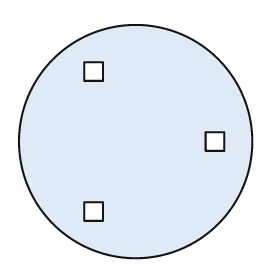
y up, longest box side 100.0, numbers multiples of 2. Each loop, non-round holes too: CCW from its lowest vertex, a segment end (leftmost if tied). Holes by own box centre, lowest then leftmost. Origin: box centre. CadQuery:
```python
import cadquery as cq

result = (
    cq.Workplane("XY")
    .moveTo(0.0, 0.0)
    .circle(50.0)
    .moveTo(-22.0, -34.0)
    .lineTo(-14.0, -34.0)
    .lineTo(-14.0, -26.0)
    .lineTo(-22.0, -26.0)
    .close()
    .moveTo(30.0, -4.0)
    .lineTo(38.0, -4.0)
    .lineTo(38.0, 4.0)
    .lineTo(30.0, 4.0)
    .close()
    .moveTo(-22.0, 26.0)
    .lineTo(-14.0, 26.0)
    .lineTo(-14.0, 34.0)
    .lineTo(-22.0, 34.0)
    .close()
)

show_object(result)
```